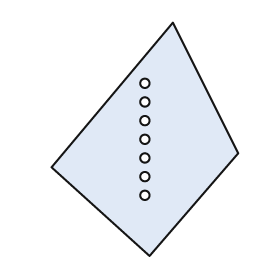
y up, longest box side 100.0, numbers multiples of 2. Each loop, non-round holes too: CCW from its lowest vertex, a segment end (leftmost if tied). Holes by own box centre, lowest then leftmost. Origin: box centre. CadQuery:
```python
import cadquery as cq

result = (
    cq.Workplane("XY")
    .moveTo(2.0, -50.0)
    .lineTo(40.0, -6.0)
    .lineTo(12.0, 50.0)
    .lineTo(-40.0, -12.0)
    .close()
    .moveTo(0.0, -24.0)
    .circle(2.0)
    .moveTo(0.0, -16.0)
    .circle(2.0)
    .moveTo(0.0, -8.0)
    .circle(2.0)
    .moveTo(0.0, 0.0)
    .circle(2.0)
    .moveTo(0.0, 8.0)
    .circle(2.0)
    .moveTo(0.0, 16.0)
    .circle(2.0)
    .moveTo(0.0, 24.0)
    .circle(2.0)
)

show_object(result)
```